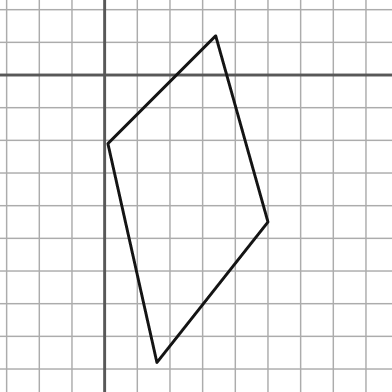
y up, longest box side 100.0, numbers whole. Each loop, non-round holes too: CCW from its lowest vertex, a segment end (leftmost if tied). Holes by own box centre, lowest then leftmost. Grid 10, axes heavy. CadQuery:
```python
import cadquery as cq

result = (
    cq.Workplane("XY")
    .moveTo(16.0, -88.0)
    .lineTo(50.0, -45.0)
    .lineTo(34.0, 12.0)
    .lineTo(1.0, -21.0)
    .close()
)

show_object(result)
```